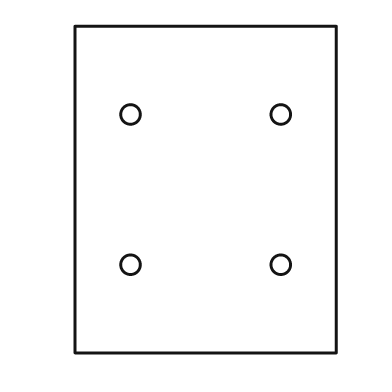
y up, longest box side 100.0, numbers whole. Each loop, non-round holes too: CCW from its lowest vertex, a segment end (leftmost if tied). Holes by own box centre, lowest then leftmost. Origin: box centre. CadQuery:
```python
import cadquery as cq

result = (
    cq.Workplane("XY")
    .moveTo(-40.0, -50.0)
    .lineTo(40.0, -50.0)
    .lineTo(40.0, 50.0)
    .lineTo(-40.0, 50.0)
    .close()
    .moveTo(-23.0, -23.0)
    .circle(3.0)
    .moveTo(23.0, -23.0)
    .circle(3.0)
    .moveTo(-23.0, 23.0)
    .circle(3.0)
    .moveTo(23.0, 23.0)
    .circle(3.0)
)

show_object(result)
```